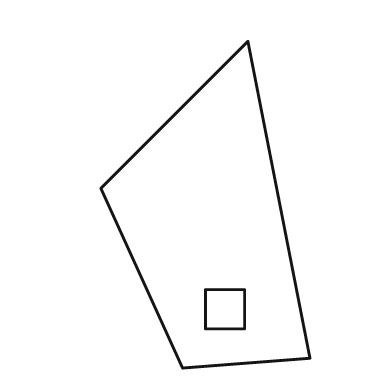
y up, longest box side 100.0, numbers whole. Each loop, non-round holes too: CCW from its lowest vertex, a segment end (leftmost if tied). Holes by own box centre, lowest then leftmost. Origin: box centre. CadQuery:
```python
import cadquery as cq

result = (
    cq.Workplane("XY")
    .moveTo(-7.0, -50.0)
    .lineTo(32.0, -47.0)
    .lineTo(13.0, 50.0)
    .lineTo(-32.0, 5.0)
    .close()
    .moveTo(0.0, -38.0)
    .lineTo(12.0, -38.0)
    .lineTo(12.0, -26.0)
    .lineTo(0.0, -26.0)
    .close()
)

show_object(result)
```